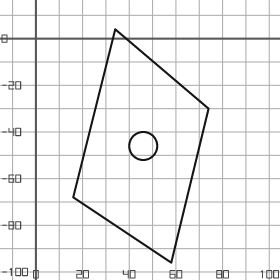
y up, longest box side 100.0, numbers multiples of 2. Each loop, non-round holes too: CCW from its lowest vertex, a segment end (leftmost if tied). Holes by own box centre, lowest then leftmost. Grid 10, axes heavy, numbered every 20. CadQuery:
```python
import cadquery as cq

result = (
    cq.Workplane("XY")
    .moveTo(58.0, -96.0)
    .lineTo(74.0, -30.0)
    .lineTo(34.0, 4.0)
    .lineTo(16.0, -68.0)
    .close()
    .moveTo(46.0, -46.0)
    .circle(6.0)
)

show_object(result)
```